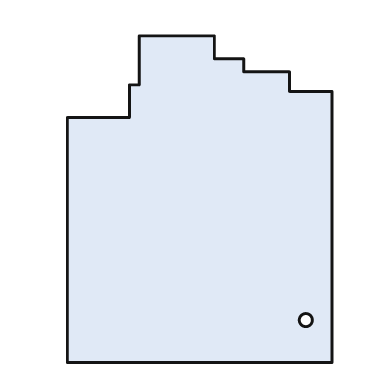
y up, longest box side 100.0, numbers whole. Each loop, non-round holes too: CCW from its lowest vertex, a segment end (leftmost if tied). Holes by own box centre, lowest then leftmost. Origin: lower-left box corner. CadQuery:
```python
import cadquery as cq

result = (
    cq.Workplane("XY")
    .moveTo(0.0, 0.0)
    .lineTo(81.0, 0.0)
    .lineTo(81.0, 83.0)
    .lineTo(68.0, 83.0)
    .lineTo(68.0, 89.0)
    .lineTo(54.0, 89.0)
    .lineTo(54.0, 93.0)
    .lineTo(45.0, 93.0)
    .lineTo(45.0, 100.0)
    .lineTo(22.0, 100.0)
    .lineTo(22.0, 85.0)
    .lineTo(19.0, 85.0)
    .lineTo(19.0, 75.0)
    .lineTo(0.0, 75.0)
    .close()
    .moveTo(73.0, 13.0)
    .circle(2.0)
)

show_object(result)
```